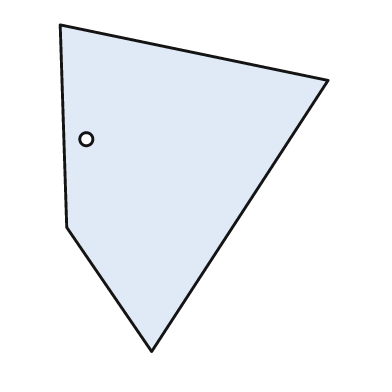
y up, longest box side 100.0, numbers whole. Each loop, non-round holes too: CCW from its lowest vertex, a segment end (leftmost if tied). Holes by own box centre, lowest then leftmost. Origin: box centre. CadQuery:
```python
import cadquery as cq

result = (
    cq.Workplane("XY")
    .moveTo(-13.0, -50.0)
    .lineTo(41.0, 33.0)
    .lineTo(-41.0, 50.0)
    .lineTo(-39.0, -12.0)
    .close()
    .moveTo(-33.0, 15.0)
    .circle(2.0)
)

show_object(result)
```